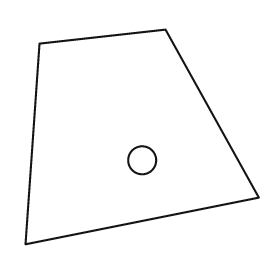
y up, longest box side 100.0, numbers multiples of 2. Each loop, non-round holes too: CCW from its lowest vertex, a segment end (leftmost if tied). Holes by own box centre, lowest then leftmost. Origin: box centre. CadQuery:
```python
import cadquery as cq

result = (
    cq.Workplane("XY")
    .moveTo(-50.0, -46.0)
    .lineTo(50.0, -26.0)
    .lineTo(10.0, 46.0)
    .lineTo(-44.0, 40.0)
    .close()
    .moveTo(0.0, -10.0)
    .circle(6.0)
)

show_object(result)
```